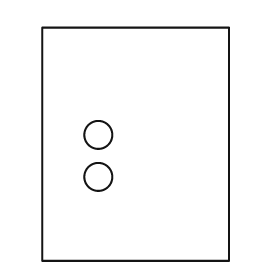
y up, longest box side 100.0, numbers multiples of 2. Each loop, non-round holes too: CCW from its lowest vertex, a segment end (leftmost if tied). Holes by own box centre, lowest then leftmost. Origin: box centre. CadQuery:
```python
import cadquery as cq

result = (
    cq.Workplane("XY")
    .moveTo(-40.0, -50.0)
    .lineTo(40.0, -50.0)
    .lineTo(40.0, 50.0)
    .lineTo(-40.0, 50.0)
    .close()
    .moveTo(-16.0, -14.0)
    .circle(6.0)
    .moveTo(-16.0, 4.0)
    .circle(6.0)
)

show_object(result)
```